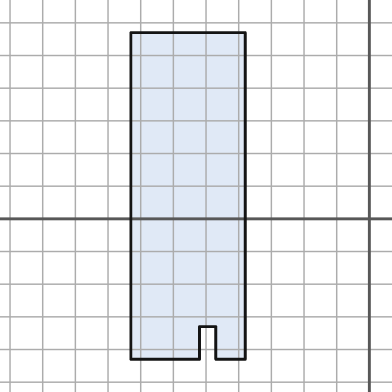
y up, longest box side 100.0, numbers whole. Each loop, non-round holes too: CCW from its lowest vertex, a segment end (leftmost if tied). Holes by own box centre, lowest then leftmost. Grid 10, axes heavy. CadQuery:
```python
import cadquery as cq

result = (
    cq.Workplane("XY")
    .moveTo(-73.0, -43.0)
    .lineTo(-52.0, -43.0)
    .lineTo(-52.0, -33.0)
    .lineTo(-47.0, -33.0)
    .lineTo(-47.0, -43.0)
    .lineTo(-38.0, -43.0)
    .lineTo(-38.0, 57.0)
    .lineTo(-73.0, 57.0)
    .close()
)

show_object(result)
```